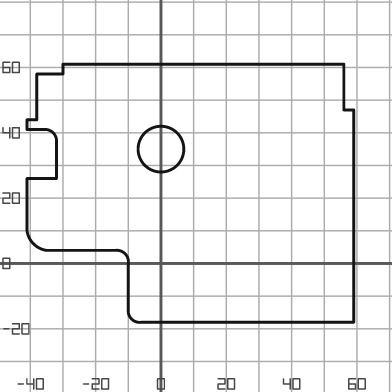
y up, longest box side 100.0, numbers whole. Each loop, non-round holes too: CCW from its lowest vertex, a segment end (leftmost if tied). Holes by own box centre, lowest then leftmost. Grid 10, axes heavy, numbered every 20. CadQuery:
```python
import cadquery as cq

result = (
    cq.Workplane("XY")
    .moveTo(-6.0, -18.0)
    .lineTo(59.0, -18.0)
    .lineTo(59.0, 47.0)
    .lineTo(56.0, 47.0)
    .lineTo(56.0, 61.0)
    .lineTo(-30.0, 61.0)
    .lineTo(-30.0, 58.0)
    .lineTo(-38.0, 58.0)
    .lineTo(-38.0, 44.0)
    .lineTo(-41.0, 44.0)
    .lineTo(-41.0, 41.0)
    .lineTo(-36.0, 41.0)
    .threePointArc((-33.0, 40.0), (-32.0, 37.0))
    .lineTo(-32.0, 26.0)
    .lineTo(-41.0, 26.0)
    .lineTo(-41.0, 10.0)
    .threePointArc((-39.0, 6.0), (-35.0, 4.0))
    .lineTo(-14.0, 4.0)
    .threePointArc((-11.0, 3.0), (-10.0, 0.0))
    .lineTo(-10.0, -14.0)
    .threePointArc((-9.0, -17.0), (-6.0, -18.0))
    .close()
    .moveTo(0.0, 35.0)
    .circle(7.0)
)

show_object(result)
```